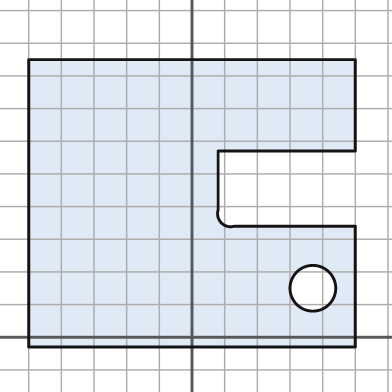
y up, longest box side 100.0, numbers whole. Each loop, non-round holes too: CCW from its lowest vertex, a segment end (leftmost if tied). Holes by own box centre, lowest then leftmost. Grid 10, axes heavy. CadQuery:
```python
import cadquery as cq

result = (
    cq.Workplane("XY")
    .moveTo(-50.0, -3.0)
    .lineTo(50.0, -3.0)
    .lineTo(50.0, 34.0)
    .lineTo(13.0, 34.0)
    .threePointArc((9.0, 35.0), (8.0, 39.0))
    .lineTo(8.0, 57.0)
    .lineTo(50.0, 57.0)
    .lineTo(50.0, 85.0)
    .lineTo(-50.0, 85.0)
    .close()
    .moveTo(37.0, 15.0)
    .circle(7.0)
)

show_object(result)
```